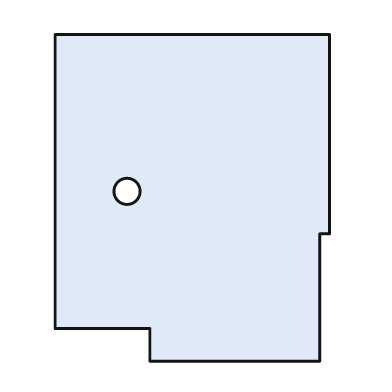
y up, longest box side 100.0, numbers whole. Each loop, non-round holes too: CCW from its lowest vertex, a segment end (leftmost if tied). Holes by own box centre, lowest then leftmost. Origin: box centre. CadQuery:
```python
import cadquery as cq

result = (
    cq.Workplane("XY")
    .moveTo(-13.0, -50.0)
    .lineTo(39.0, -50.0)
    .lineTo(39.0, -11.0)
    .lineTo(42.0, -11.0)
    .lineTo(42.0, 50.0)
    .lineTo(-42.0, 50.0)
    .lineTo(-42.0, -40.0)
    .lineTo(-13.0, -40.0)
    .close()
    .moveTo(-20.0, 2.0)
    .circle(4.0)
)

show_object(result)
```